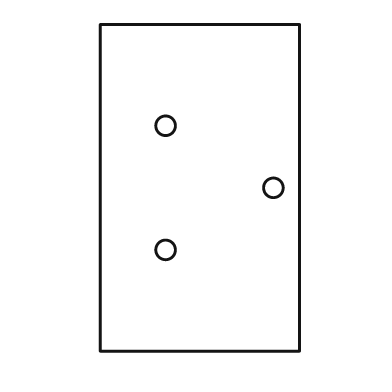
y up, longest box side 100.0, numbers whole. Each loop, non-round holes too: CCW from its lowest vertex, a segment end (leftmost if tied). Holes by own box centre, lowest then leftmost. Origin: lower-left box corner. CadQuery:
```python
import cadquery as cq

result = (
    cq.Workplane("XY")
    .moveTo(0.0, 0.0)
    .lineTo(61.0, 0.0)
    .lineTo(61.0, 100.0)
    .lineTo(0.0, 100.0)
    .close()
    .moveTo(20.0, 31.0)
    .circle(3.0)
    .moveTo(53.0, 50.0)
    .circle(3.0)
    .moveTo(20.0, 69.0)
    .circle(3.0)
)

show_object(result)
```